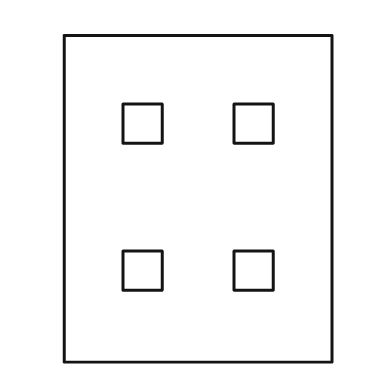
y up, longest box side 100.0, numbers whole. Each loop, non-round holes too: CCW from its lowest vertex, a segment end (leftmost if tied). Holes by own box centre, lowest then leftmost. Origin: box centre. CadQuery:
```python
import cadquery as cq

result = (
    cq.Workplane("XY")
    .moveTo(-41.0, -50.0)
    .lineTo(41.0, -50.0)
    .lineTo(41.0, 50.0)
    .lineTo(-41.0, 50.0)
    .close()
    .moveTo(-23.0, -28.0)
    .lineTo(-11.0, -28.0)
    .lineTo(-11.0, -16.0)
    .lineTo(-23.0, -16.0)
    .close()
    .moveTo(11.0, -28.0)
    .lineTo(23.0, -28.0)
    .lineTo(23.0, -16.0)
    .lineTo(11.0, -16.0)
    .close()
    .moveTo(-23.0, 17.0)
    .lineTo(-11.0, 17.0)
    .lineTo(-11.0, 29.0)
    .lineTo(-23.0, 29.0)
    .close()
    .moveTo(11.0, 17.0)
    .lineTo(23.0, 17.0)
    .lineTo(23.0, 29.0)
    .lineTo(11.0, 29.0)
    .close()
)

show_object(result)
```